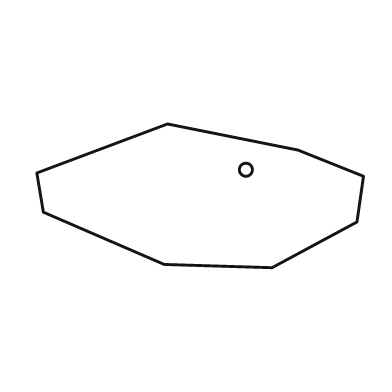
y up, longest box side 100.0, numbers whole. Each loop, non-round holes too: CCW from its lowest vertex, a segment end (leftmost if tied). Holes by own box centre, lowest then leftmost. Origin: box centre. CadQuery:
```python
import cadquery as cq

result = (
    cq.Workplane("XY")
    .moveTo(22.0, -22.0)
    .lineTo(48.0, -8.0)
    .lineTo(50.0, 6.0)
    .lineTo(30.0, 14.0)
    .lineTo(-10.0, 22.0)
    .lineTo(-50.0, 7.0)
    .lineTo(-48.0, -5.0)
    .lineTo(-11.0, -21.0)
    .close()
    .moveTo(14.0, 8.0)
    .circle(2.0)
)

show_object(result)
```